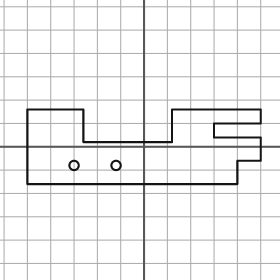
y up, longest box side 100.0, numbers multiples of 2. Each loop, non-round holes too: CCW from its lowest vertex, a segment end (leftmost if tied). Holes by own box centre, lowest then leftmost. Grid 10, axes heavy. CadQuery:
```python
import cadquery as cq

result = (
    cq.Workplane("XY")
    .moveTo(-50.0, -16.0)
    .lineTo(40.0, -16.0)
    .lineTo(40.0, -6.0)
    .lineTo(50.0, -6.0)
    .lineTo(50.0, 4.0)
    .lineTo(30.0, 4.0)
    .lineTo(30.0, 10.0)
    .lineTo(50.0, 10.0)
    .lineTo(50.0, 16.0)
    .lineTo(12.0, 16.0)
    .lineTo(12.0, 2.0)
    .lineTo(-26.0, 2.0)
    .lineTo(-26.0, 16.0)
    .lineTo(-50.0, 16.0)
    .close()
    .moveTo(-30.0, -8.0)
    .circle(2.0)
    .moveTo(-12.0, -8.0)
    .circle(2.0)
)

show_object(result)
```